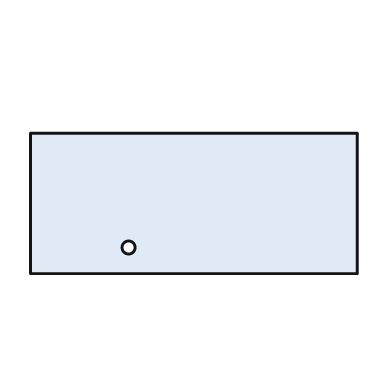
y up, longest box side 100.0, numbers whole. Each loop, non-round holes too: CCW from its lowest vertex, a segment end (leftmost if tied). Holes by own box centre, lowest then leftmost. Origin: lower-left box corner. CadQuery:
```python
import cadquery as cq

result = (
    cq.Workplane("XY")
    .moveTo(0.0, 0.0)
    .lineTo(100.0, 0.0)
    .lineTo(100.0, 43.0)
    .lineTo(0.0, 43.0)
    .close()
    .moveTo(30.0, 8.0)
    .circle(2.0)
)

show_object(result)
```